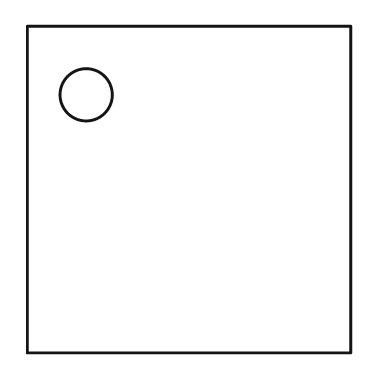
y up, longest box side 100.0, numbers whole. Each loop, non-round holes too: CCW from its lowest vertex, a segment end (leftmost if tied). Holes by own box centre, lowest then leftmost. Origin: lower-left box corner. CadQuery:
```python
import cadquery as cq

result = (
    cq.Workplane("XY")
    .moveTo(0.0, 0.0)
    .lineTo(99.0, 0.0)
    .lineTo(99.0, 100.0)
    .lineTo(0.0, 100.0)
    .close()
    .moveTo(18.0, 79.0)
    .circle(8.0)
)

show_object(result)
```